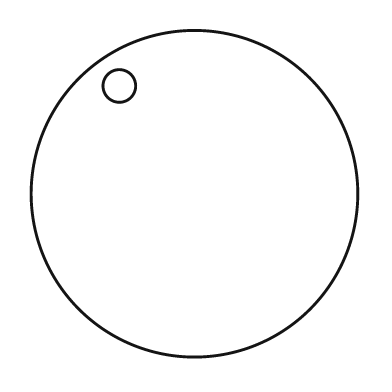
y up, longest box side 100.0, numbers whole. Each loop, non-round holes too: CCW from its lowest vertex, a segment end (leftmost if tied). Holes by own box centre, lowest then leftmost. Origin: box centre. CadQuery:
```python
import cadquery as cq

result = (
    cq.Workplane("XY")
    .moveTo(0.0, 0.0)
    .circle(50.0)
    .moveTo(-23.0, 33.0)
    .circle(5.0)
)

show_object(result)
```